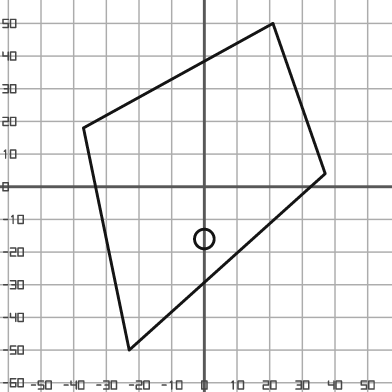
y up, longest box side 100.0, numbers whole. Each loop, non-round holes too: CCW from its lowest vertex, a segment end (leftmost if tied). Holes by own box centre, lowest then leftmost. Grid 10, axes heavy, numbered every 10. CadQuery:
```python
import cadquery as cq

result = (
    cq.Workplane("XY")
    .moveTo(-23.0, -50.0)
    .lineTo(37.0, 4.0)
    .lineTo(21.0, 50.0)
    .lineTo(-37.0, 18.0)
    .close()
    .moveTo(0.0, -16.0)
    .circle(3.0)
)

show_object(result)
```